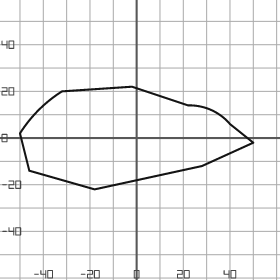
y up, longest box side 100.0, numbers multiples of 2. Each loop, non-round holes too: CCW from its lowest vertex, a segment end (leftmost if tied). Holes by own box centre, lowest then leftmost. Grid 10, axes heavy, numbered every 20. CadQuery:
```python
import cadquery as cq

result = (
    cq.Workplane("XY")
    .moveTo(-18.0, -22.0)
    .lineTo(28.0, -12.0)
    .lineTo(50.0, -2.0)
    .lineTo(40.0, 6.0)
    .threePointArc((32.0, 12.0), (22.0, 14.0))
    .lineTo(-2.0, 22.0)
    .lineTo(-32.0, 20.0)
    .threePointArc((-42.0, 12.0), (-50.0, 2.0))
    .lineTo(-46.0, -14.0)
    .close()
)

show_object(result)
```